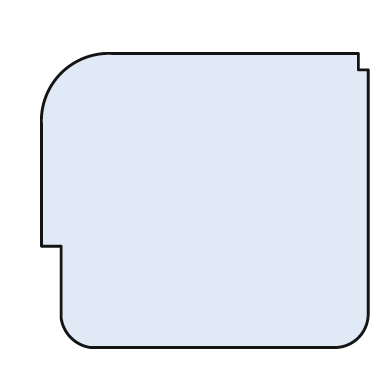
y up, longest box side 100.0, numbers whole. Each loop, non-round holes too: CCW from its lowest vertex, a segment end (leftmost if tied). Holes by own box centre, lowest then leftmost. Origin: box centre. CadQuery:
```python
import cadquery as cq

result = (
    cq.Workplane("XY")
    .moveTo(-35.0, -45.0)
    .lineTo(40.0, -45.0)
    .threePointArc((47.0, -42.0), (50.0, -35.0))
    .lineTo(50.0, 40.0)
    .lineTo(47.0, 40.0)
    .lineTo(47.0, 45.0)
    .lineTo(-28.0, 45.0)
    .threePointArc((-44.0, 39.0), (-50.0, 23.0))
    .lineTo(-50.0, -14.0)
    .lineTo(-44.0, -14.0)
    .lineTo(-44.0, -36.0)
    .threePointArc((-41.0, -42.0), (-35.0, -45.0))
    .close()
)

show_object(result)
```